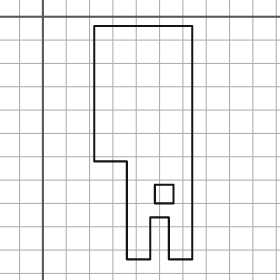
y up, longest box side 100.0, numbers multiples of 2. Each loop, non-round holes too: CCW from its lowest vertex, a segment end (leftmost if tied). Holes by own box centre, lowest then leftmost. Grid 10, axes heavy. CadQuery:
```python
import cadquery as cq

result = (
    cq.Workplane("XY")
    .moveTo(36.0, -104.0)
    .lineTo(46.0, -104.0)
    .lineTo(46.0, -86.0)
    .lineTo(54.0, -86.0)
    .lineTo(54.0, -104.0)
    .lineTo(64.0, -104.0)
    .lineTo(64.0, -4.0)
    .lineTo(22.0, -4.0)
    .lineTo(22.0, -62.0)
    .lineTo(36.0, -62.0)
    .close()
    .moveTo(48.0, -80.0)
    .lineTo(56.0, -80.0)
    .lineTo(56.0, -72.0)
    .lineTo(48.0, -72.0)
    .close()
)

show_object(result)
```